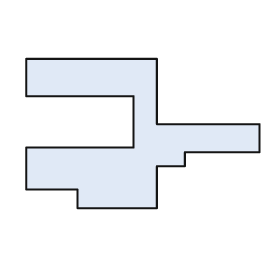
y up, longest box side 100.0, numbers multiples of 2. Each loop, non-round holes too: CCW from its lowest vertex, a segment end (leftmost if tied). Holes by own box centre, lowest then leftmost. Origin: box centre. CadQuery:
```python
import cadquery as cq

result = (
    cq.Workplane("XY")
    .moveTo(-28.0, -32.0)
    .lineTo(6.0, -32.0)
    .lineTo(6.0, -14.0)
    .lineTo(18.0, -14.0)
    .lineTo(18.0, -8.0)
    .lineTo(50.0, -8.0)
    .lineTo(50.0, 4.0)
    .lineTo(6.0, 4.0)
    .lineTo(6.0, 32.0)
    .lineTo(-50.0, 32.0)
    .lineTo(-50.0, 16.0)
    .lineTo(-4.0, 16.0)
    .lineTo(-4.0, -6.0)
    .lineTo(-50.0, -6.0)
    .lineTo(-50.0, -24.0)
    .lineTo(-28.0, -24.0)
    .close()
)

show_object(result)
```